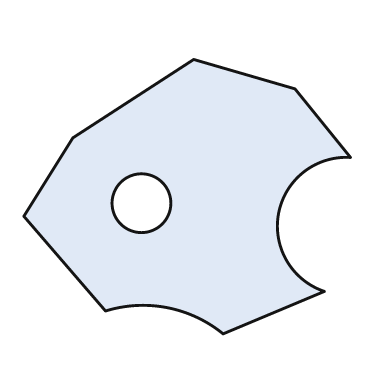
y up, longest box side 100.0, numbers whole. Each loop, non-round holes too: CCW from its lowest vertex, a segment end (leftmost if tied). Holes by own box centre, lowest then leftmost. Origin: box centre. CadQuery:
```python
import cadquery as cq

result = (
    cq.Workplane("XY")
    .moveTo(11.0, -42.0)
    .lineTo(42.0, -29.0)
    .threePointArc((28.0, -5.0), (50.0, 12.0))
    .lineTo(33.0, 33.0)
    .lineTo(2.0, 42.0)
    .lineTo(-35.0, 18.0)
    .lineTo(-50.0, -6.0)
    .lineTo(-25.0, -35.0)
    .threePointArc((-6.0, -34.0), (11.0, -42.0))
    .close()
    .moveTo(-14.0, -2.0)
    .circle(9.0)
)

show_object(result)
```